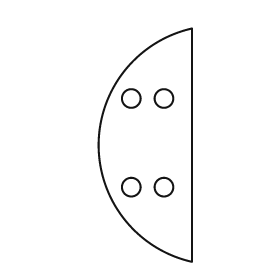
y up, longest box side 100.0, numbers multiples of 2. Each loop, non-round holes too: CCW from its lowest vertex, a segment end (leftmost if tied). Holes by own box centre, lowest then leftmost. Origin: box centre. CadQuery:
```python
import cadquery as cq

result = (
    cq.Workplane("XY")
    .moveTo(20.0, -50.0)
    .lineTo(20.0, 50.0)
    .threePointArc((-20.0, 0.0), (20.0, -50.0))
    .close()
    .moveTo(-6.0, -18.0)
    .circle(4.0)
    .moveTo(8.0, -18.0)
    .circle(4.0)
    .moveTo(-6.0, 20.0)
    .circle(4.0)
    .moveTo(8.0, 20.0)
    .circle(4.0)
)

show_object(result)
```